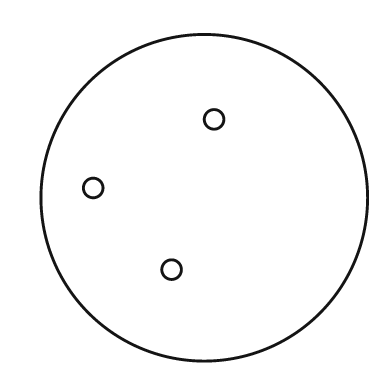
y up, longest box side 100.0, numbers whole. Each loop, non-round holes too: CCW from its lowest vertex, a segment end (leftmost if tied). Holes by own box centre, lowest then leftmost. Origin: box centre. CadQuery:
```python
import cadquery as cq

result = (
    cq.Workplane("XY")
    .moveTo(0.0, 0.0)
    .circle(50.0)
    .moveTo(-10.0, -22.0)
    .circle(3.0)
    .moveTo(-34.0, 3.0)
    .circle(3.0)
    .moveTo(3.0, 24.0)
    .circle(3.0)
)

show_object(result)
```